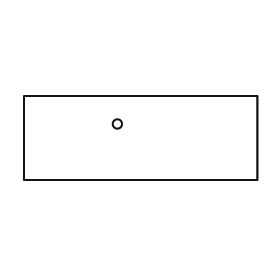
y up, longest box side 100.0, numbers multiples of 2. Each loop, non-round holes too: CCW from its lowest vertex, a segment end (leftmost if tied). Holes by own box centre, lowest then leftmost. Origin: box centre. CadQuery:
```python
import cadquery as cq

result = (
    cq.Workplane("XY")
    .moveTo(-50.0, -18.0)
    .lineTo(50.0, -18.0)
    .lineTo(50.0, 18.0)
    .lineTo(-50.0, 18.0)
    .close()
    .moveTo(-10.0, 6.0)
    .circle(2.0)
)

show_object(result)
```